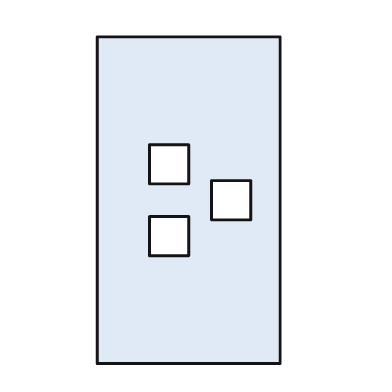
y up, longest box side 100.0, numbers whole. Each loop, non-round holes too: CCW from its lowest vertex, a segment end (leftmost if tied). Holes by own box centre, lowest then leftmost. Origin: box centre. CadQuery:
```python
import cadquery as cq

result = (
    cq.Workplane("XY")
    .moveTo(-28.0, -50.0)
    .lineTo(28.0, -50.0)
    .lineTo(28.0, 50.0)
    .lineTo(-28.0, 50.0)
    .close()
    .moveTo(-12.0, -17.0)
    .lineTo(0.0, -17.0)
    .lineTo(0.0, -5.0)
    .lineTo(-12.0, -5.0)
    .close()
    .moveTo(7.0, -6.0)
    .lineTo(19.0, -6.0)
    .lineTo(19.0, 6.0)
    .lineTo(7.0, 6.0)
    .close()
    .moveTo(-12.0, 5.0)
    .lineTo(0.0, 5.0)
    .lineTo(0.0, 17.0)
    .lineTo(-12.0, 17.0)
    .close()
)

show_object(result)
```